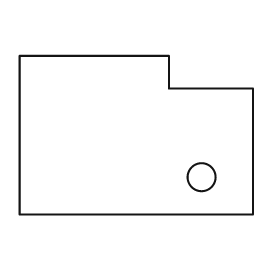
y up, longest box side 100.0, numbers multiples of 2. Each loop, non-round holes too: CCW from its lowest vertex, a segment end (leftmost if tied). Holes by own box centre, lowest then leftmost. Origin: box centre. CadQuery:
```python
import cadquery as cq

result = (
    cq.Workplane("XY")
    .moveTo(-50.0, -34.0)
    .lineTo(50.0, -34.0)
    .lineTo(50.0, 20.0)
    .lineTo(14.0, 20.0)
    .lineTo(14.0, 34.0)
    .lineTo(-50.0, 34.0)
    .close()
    .moveTo(28.0, -18.0)
    .circle(6.0)
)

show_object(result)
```